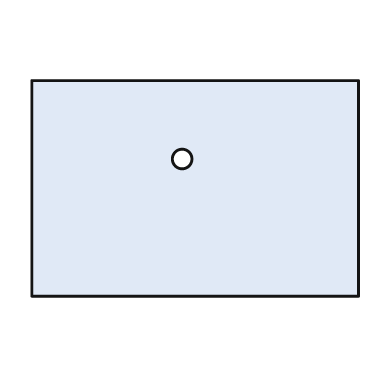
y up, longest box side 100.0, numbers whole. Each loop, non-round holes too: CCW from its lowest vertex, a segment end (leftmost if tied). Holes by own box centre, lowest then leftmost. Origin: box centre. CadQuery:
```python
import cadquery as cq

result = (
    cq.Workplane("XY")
    .moveTo(-50.0, -33.0)
    .lineTo(50.0, -33.0)
    .lineTo(50.0, 33.0)
    .lineTo(-50.0, 33.0)
    .close()
    .moveTo(-4.0, 9.0)
    .circle(3.0)
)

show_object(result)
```